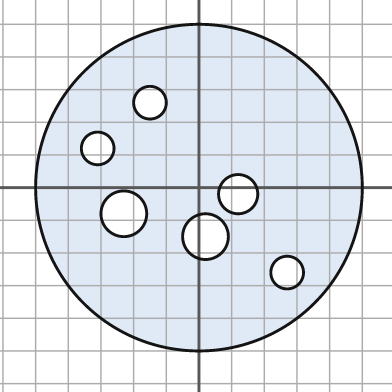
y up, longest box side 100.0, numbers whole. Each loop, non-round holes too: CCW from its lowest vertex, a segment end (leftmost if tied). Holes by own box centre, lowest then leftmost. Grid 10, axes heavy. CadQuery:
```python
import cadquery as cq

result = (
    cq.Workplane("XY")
    .moveTo(0.0, 0.0)
    .circle(50.0)
    .moveTo(27.0, -26.0)
    .circle(5.0)
    .moveTo(2.0, -15.0)
    .circle(7.0)
    .moveTo(-23.0, -8.0)
    .circle(7.0)
    .moveTo(12.0, -2.0)
    .circle(6.0)
    .moveTo(-31.0, 12.0)
    .circle(5.0)
    .moveTo(-15.0, 26.0)
    .circle(5.0)
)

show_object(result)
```